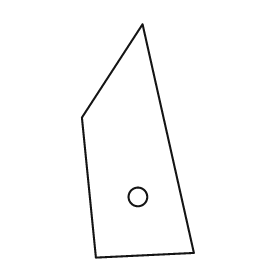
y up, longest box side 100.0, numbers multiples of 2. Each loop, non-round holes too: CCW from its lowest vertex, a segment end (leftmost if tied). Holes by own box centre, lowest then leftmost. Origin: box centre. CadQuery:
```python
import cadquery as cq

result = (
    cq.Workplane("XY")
    .moveTo(-18.0, -50.0)
    .lineTo(24.0, -48.0)
    .lineTo(2.0, 50.0)
    .lineTo(-24.0, 10.0)
    .close()
    .moveTo(0.0, -24.0)
    .circle(4.0)
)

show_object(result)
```